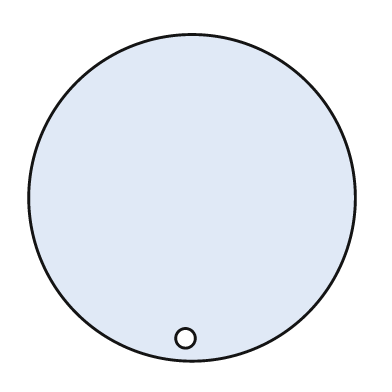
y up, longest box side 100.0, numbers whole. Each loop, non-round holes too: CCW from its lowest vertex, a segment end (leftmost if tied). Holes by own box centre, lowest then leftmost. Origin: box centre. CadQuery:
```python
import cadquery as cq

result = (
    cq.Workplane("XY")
    .moveTo(0.0, 0.0)
    .circle(50.0)
    .moveTo(-2.0, -43.0)
    .circle(3.0)
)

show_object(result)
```